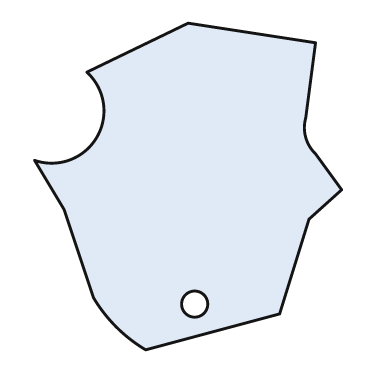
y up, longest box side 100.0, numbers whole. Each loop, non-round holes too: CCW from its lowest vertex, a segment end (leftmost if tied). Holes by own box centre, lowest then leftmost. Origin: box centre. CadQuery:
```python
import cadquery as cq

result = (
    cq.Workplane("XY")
    .moveTo(-13.0, -50.0)
    .lineTo(28.0, -39.0)
    .lineTo(37.0, -10.0)
    .lineTo(47.0, -1.0)
    .lineTo(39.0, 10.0)
    .threePointArc((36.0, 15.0), (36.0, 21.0))
    .lineTo(39.0, 44.0)
    .lineTo(0.0, 50.0)
    .lineTo(-31.0, 35.0)
    .threePointArc((-28.0, 15.0), (-47.0, 8.0))
    .lineTo(-38.0, -7.0)
    .lineTo(-29.0, -34.0)
    .threePointArc((-22.0, -43.0), (-13.0, -50.0))
    .close()
    .moveTo(2.0, -36.0)
    .circle(4.0)
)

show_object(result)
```